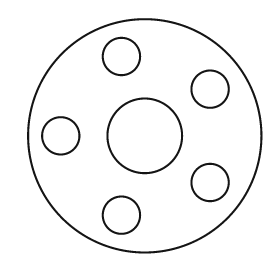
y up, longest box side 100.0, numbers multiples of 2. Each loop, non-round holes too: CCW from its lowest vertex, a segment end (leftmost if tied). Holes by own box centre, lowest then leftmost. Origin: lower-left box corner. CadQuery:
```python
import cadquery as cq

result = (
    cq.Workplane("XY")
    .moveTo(50.0, 50.0)
    .circle(50.0)
    .moveTo(40.0, 16.0)
    .circle(8.0)
    .moveTo(78.0, 30.0)
    .circle(8.0)
    .moveTo(14.0, 50.0)
    .circle(8.0)
    .moveTo(50.0, 50.0)
    .circle(16.0)
    .moveTo(78.0, 70.0)
    .circle(8.0)
    .moveTo(40.0, 84.0)
    .circle(8.0)
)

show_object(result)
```